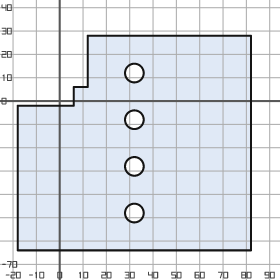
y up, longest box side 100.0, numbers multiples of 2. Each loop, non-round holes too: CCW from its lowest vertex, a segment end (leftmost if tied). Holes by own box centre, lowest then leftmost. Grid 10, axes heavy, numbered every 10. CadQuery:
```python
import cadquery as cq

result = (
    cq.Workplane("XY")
    .moveTo(-18.0, -64.0)
    .lineTo(82.0, -64.0)
    .lineTo(82.0, 28.0)
    .lineTo(12.0, 28.0)
    .lineTo(12.0, 6.0)
    .lineTo(6.0, 6.0)
    .lineTo(6.0, -2.0)
    .lineTo(-18.0, -2.0)
    .close()
    .moveTo(32.0, -48.0)
    .circle(4.0)
    .moveTo(32.0, -28.0)
    .circle(4.0)
    .moveTo(32.0, -8.0)
    .circle(4.0)
    .moveTo(32.0, 12.0)
    .circle(4.0)
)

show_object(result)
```